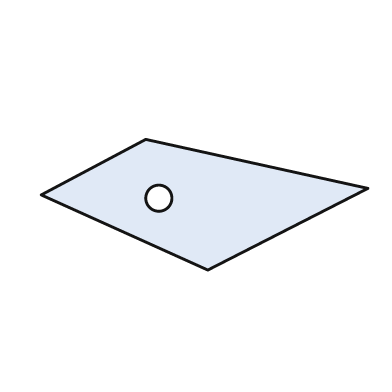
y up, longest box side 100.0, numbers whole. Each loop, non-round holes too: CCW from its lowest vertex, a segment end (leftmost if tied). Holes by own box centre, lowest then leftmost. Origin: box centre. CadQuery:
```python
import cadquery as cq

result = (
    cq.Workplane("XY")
    .moveTo(1.0, -20.0)
    .lineTo(50.0, 5.0)
    .lineTo(-18.0, 20.0)
    .lineTo(-50.0, 3.0)
    .close()
    .moveTo(-14.0, 2.0)
    .circle(4.0)
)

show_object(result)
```